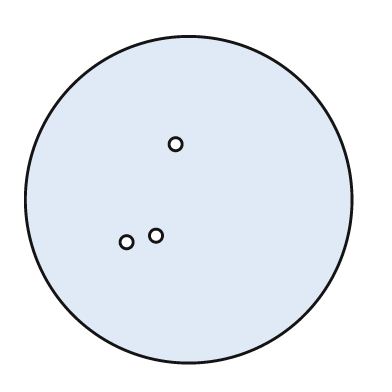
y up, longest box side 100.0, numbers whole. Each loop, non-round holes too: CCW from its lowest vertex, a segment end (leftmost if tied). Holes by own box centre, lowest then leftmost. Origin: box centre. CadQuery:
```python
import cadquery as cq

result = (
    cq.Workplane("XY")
    .moveTo(0.0, 0.0)
    .circle(50.0)
    .moveTo(-19.0, -13.0)
    .circle(2.0)
    .moveTo(-10.0, -11.0)
    .circle(2.0)
    .moveTo(-4.0, 17.0)
    .circle(2.0)
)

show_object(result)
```